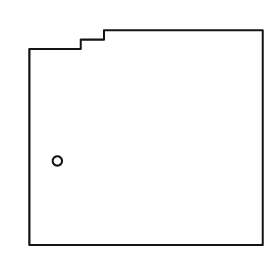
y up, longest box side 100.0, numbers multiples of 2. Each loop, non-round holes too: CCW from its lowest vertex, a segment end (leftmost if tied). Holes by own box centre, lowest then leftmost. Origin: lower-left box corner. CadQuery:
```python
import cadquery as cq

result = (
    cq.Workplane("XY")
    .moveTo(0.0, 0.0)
    .lineTo(100.0, 0.0)
    .lineTo(100.0, 92.0)
    .lineTo(32.0, 92.0)
    .lineTo(32.0, 88.0)
    .lineTo(22.0, 88.0)
    .lineTo(22.0, 84.0)
    .lineTo(0.0, 84.0)
    .close()
    .moveTo(12.0, 36.0)
    .circle(2.0)
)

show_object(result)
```